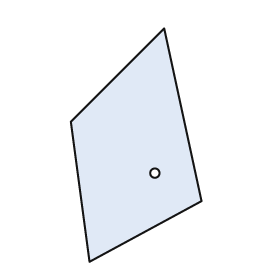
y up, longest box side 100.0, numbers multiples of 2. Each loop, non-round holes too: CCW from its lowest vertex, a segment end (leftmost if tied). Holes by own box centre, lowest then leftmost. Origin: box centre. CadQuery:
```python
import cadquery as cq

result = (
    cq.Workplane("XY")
    .moveTo(-20.0, -50.0)
    .lineTo(28.0, -24.0)
    .lineTo(12.0, 50.0)
    .lineTo(-28.0, 10.0)
    .close()
    .moveTo(8.0, -12.0)
    .circle(2.0)
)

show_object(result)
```